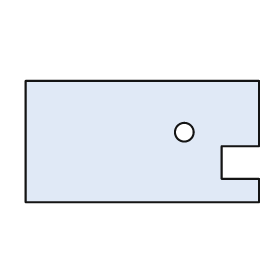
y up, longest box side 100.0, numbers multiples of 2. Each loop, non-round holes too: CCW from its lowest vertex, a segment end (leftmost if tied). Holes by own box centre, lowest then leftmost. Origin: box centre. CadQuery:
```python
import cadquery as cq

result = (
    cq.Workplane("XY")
    .moveTo(-50.0, -26.0)
    .lineTo(50.0, -26.0)
    .lineTo(50.0, -16.0)
    .lineTo(34.0, -16.0)
    .lineTo(34.0, -2.0)
    .lineTo(50.0, -2.0)
    .lineTo(50.0, 26.0)
    .lineTo(-50.0, 26.0)
    .close()
    .moveTo(18.0, 4.0)
    .circle(4.0)
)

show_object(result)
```